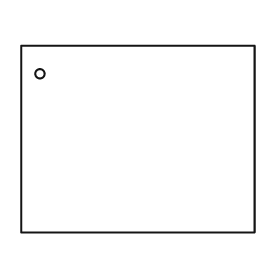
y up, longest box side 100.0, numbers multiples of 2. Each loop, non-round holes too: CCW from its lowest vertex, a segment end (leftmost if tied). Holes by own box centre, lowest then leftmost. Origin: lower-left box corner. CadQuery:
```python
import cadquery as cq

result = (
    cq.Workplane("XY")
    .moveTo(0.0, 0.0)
    .lineTo(100.0, 0.0)
    .lineTo(100.0, 80.0)
    .lineTo(0.0, 80.0)
    .close()
    .moveTo(8.0, 68.0)
    .circle(2.0)
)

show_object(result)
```